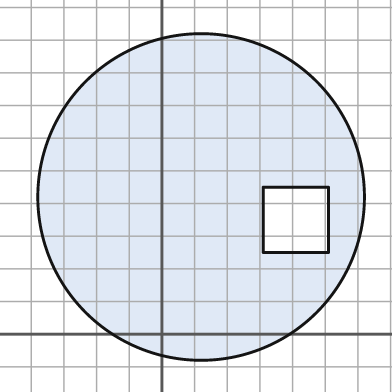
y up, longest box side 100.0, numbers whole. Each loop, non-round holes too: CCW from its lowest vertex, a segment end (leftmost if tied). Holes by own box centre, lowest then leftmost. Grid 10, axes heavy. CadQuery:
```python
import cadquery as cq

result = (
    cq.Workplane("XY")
    .moveTo(12.0, 42.0)
    .circle(50.0)
    .moveTo(31.0, 25.0)
    .lineTo(51.0, 25.0)
    .lineTo(51.0, 45.0)
    .lineTo(31.0, 45.0)
    .close()
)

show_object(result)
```